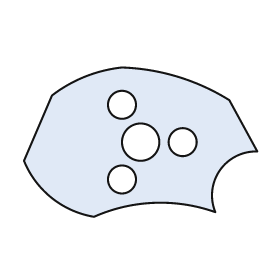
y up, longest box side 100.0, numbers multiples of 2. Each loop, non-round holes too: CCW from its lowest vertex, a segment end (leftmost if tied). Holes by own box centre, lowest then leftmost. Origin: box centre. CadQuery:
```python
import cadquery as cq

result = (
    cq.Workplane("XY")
    .moveTo(-20.0, -32.0)
    .threePointArc((6.0, -26.0), (32.0, -30.0))
    .threePointArc((34.0, -12.0), (50.0, -4.0))
    .lineTo(38.0, 18.0)
    .threePointArc((16.0, 28.0), (-8.0, 32.0))
    .threePointArc((-24.0, 28.0), (-38.0, 20.0))
    .lineTo(-50.0, -8.0)
    .threePointArc((-38.0, -24.0), (-20.0, -32.0))
    .close()
    .moveTo(-8.0, -16.0)
    .circle(6.0)
    .moveTo(0.0, 0.0)
    .circle(8.0)
    .moveTo(18.0, 0.0)
    .circle(6.0)
    .moveTo(-8.0, 16.0)
    .circle(6.0)
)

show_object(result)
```